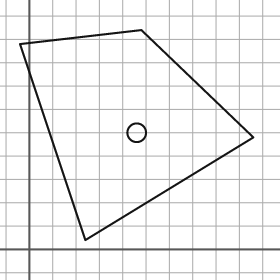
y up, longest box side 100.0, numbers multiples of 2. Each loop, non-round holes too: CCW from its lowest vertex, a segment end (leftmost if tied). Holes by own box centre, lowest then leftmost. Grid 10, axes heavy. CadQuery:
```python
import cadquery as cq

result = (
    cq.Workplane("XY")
    .moveTo(24.0, 4.0)
    .lineTo(96.0, 48.0)
    .lineTo(48.0, 94.0)
    .lineTo(-4.0, 88.0)
    .close()
    .moveTo(46.0, 50.0)
    .circle(4.0)
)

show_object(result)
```